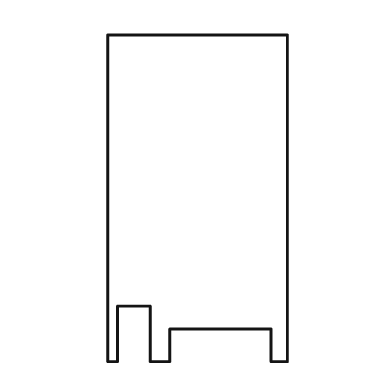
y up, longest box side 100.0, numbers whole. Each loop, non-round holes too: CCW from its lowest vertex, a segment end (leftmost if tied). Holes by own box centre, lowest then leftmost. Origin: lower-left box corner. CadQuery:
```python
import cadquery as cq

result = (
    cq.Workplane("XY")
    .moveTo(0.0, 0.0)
    .lineTo(3.0, 0.0)
    .lineTo(3.0, 17.0)
    .lineTo(13.0, 17.0)
    .lineTo(13.0, 0.0)
    .lineTo(19.0, 0.0)
    .lineTo(19.0, 10.0)
    .lineTo(50.0, 10.0)
    .lineTo(50.0, 0.0)
    .lineTo(55.0, 0.0)
    .lineTo(55.0, 100.0)
    .lineTo(0.0, 100.0)
    .close()
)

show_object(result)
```